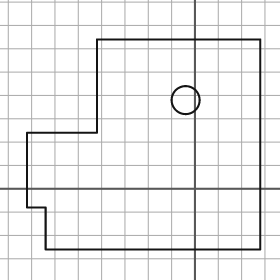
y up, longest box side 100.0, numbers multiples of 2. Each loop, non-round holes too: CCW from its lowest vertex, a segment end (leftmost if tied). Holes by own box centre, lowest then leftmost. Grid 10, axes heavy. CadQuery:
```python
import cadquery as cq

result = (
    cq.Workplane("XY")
    .moveTo(-64.0, -26.0)
    .lineTo(28.0, -26.0)
    .lineTo(28.0, 64.0)
    .lineTo(-42.0, 64.0)
    .lineTo(-42.0, 24.0)
    .lineTo(-72.0, 24.0)
    .lineTo(-72.0, -8.0)
    .lineTo(-64.0, -8.0)
    .close()
    .moveTo(-4.0, 38.0)
    .circle(6.0)
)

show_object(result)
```